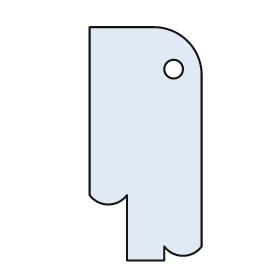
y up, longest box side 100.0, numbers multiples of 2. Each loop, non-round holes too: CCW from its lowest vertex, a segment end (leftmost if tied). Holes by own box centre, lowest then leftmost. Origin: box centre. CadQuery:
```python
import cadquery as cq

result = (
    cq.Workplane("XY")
    .moveTo(-8.0, -50.0)
    .lineTo(8.0, -50.0)
    .lineTo(8.0, -44.0)
    .threePointArc((16.0, -48.0), (24.0, -44.0))
    .lineTo(24.0, 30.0)
    .threePointArc((18.0, 44.0), (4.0, 50.0))
    .lineTo(-24.0, 50.0)
    .lineTo(-24.0, -22.0)
    .threePointArc((-16.0, -26.0), (-8.0, -22.0))
    .close()
    .moveTo(12.0, 32.0)
    .circle(4.0)
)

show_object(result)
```